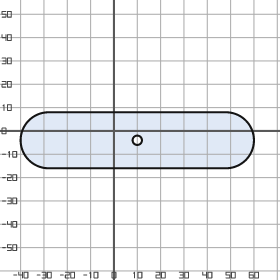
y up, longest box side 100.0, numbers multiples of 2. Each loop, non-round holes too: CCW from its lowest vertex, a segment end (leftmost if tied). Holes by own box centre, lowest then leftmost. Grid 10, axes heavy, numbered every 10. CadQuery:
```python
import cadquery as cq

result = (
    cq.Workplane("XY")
    .moveTo(-28.0, -16.0)
    .lineTo(48.0, -16.0)
    .threePointArc((60.0, -4.0), (48.0, 8.0))
    .lineTo(-28.0, 8.0)
    .threePointArc((-40.0, -4.0), (-28.0, -16.0))
    .close()
    .moveTo(10.0, -4.0)
    .circle(2.0)
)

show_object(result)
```